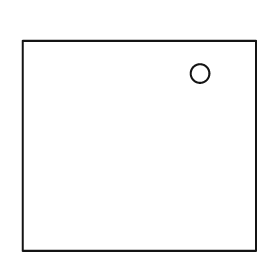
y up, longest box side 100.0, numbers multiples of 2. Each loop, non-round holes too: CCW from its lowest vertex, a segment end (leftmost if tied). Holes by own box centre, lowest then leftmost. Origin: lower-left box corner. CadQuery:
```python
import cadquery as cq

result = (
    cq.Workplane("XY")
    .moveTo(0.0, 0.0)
    .lineTo(100.0, 0.0)
    .lineTo(100.0, 90.0)
    .lineTo(0.0, 90.0)
    .close()
    .moveTo(76.0, 76.0)
    .circle(4.0)
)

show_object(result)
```